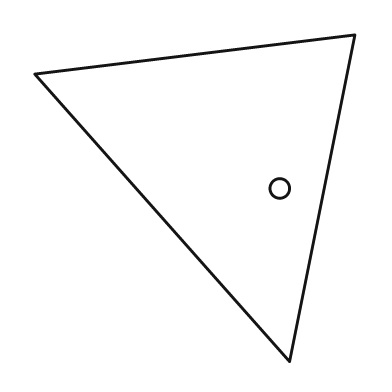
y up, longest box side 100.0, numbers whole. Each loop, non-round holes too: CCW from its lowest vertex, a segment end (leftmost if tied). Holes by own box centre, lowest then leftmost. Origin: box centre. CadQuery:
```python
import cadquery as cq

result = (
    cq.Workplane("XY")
    .moveTo(29.0, -50.0)
    .lineTo(49.0, 50.0)
    .lineTo(-49.0, 38.0)
    .close()
    .moveTo(26.0, 3.0)
    .circle(3.0)
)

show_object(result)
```